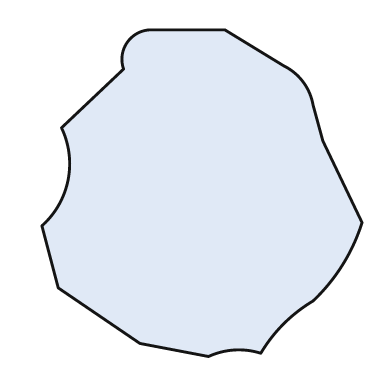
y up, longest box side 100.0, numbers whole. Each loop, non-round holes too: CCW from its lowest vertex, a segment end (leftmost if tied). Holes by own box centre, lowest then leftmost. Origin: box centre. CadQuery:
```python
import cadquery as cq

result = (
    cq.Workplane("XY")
    .moveTo(2.0, -50.0)
    .threePointArc((10.0, -48.0), (18.0, -49.0))
    .threePointArc((25.0, -40.0), (34.0, -33.0))
    .threePointArc((43.0, -22.0), (49.0, -9.0))
    .lineTo(37.0, 16.0)
    .lineTo(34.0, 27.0)
    .threePointArc((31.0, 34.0), (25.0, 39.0))
    .lineTo(7.0, 50.0)
    .lineTo(-16.0, 50.0)
    .threePointArc((-23.0, 46.0), (-24.0, 38.0))
    .lineTo(-43.0, 20.0)
    .threePointArc((-41.0, 4.0), (-49.0, -10.0))
    .lineTo(-44.0, -29.0)
    .lineTo(-19.0, -46.0)
    .close()
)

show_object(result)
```